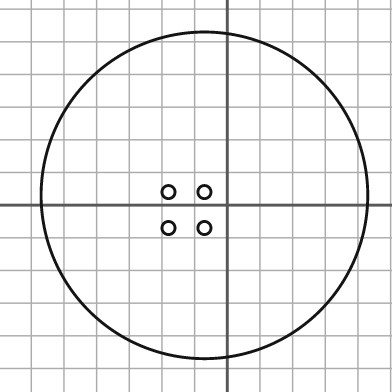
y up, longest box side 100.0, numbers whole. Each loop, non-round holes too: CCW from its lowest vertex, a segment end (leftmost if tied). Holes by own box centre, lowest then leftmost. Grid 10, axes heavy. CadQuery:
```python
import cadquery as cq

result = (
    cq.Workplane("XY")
    .moveTo(-7.0, 3.0)
    .circle(50.0)
    .moveTo(-18.0, -7.0)
    .circle(2.0)
    .moveTo(-7.0, -7.0)
    .circle(2.0)
    .moveTo(-18.0, 4.0)
    .circle(2.0)
    .moveTo(-7.0, 4.0)
    .circle(2.0)
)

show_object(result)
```